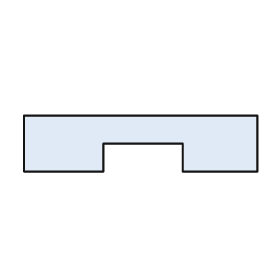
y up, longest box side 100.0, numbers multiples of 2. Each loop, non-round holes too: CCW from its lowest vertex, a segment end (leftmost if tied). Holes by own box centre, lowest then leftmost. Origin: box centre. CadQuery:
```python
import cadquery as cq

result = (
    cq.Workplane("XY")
    .moveTo(-50.0, -12.0)
    .lineTo(-16.0, -12.0)
    .lineTo(-16.0, 0.0)
    .lineTo(18.0, 0.0)
    .lineTo(18.0, -12.0)
    .lineTo(50.0, -12.0)
    .lineTo(50.0, 12.0)
    .lineTo(-50.0, 12.0)
    .close()
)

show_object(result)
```